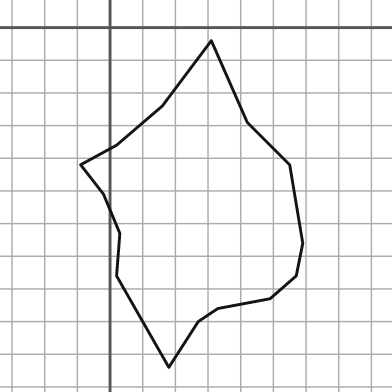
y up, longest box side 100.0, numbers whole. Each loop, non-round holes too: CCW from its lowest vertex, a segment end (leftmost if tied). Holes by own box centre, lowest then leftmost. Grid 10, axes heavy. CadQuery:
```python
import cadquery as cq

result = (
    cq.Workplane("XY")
    .moveTo(18.0, -104.0)
    .lineTo(27.0, -90.0)
    .lineTo(33.0, -86.0)
    .lineTo(49.0, -83.0)
    .lineTo(57.0, -76.0)
    .lineTo(59.0, -66.0)
    .lineTo(55.0, -42.0)
    .lineTo(42.0, -29.0)
    .lineTo(31.0, -4.0)
    .lineTo(16.0, -24.0)
    .lineTo(2.0, -36.0)
    .lineTo(-9.0, -42.0)
    .lineTo(-2.0, -51.0)
    .lineTo(3.0, -63.0)
    .lineTo(2.0, -76.0)
    .close()
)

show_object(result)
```